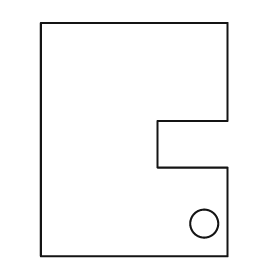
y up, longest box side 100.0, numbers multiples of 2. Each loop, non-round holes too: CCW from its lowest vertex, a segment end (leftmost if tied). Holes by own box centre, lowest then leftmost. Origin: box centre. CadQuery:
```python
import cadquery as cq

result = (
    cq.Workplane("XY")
    .moveTo(-40.0, -50.0)
    .lineTo(40.0, -50.0)
    .lineTo(40.0, -12.0)
    .lineTo(10.0, -12.0)
    .lineTo(10.0, 8.0)
    .lineTo(40.0, 8.0)
    .lineTo(40.0, 50.0)
    .lineTo(-40.0, 50.0)
    .close()
    .moveTo(30.0, -36.0)
    .circle(6.0)
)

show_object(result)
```